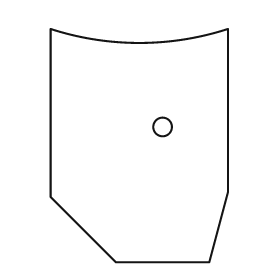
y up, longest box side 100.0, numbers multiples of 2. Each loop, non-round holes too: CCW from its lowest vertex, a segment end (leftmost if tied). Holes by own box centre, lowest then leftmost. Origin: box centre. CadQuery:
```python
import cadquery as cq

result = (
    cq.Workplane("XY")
    .moveTo(-10.0, -50.0)
    .lineTo(30.0, -50.0)
    .lineTo(38.0, -20.0)
    .lineTo(38.0, 50.0)
    .threePointArc((0.0, 44.0), (-38.0, 50.0))
    .lineTo(-38.0, -22.0)
    .close()
    .moveTo(10.0, 8.0)
    .circle(4.0)
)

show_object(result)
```